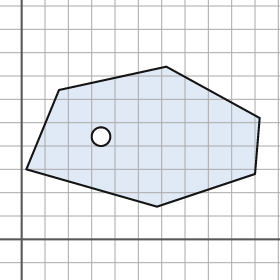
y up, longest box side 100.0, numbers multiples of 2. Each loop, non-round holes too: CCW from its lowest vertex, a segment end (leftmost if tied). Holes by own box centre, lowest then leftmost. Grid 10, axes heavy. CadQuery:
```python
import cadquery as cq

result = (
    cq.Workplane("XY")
    .moveTo(58.0, 14.0)
    .lineTo(100.0, 28.0)
    .lineTo(102.0, 52.0)
    .lineTo(62.0, 74.0)
    .lineTo(16.0, 64.0)
    .lineTo(2.0, 30.0)
    .close()
    .moveTo(34.0, 44.0)
    .circle(4.0)
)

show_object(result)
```